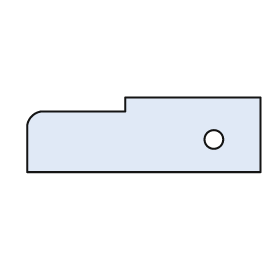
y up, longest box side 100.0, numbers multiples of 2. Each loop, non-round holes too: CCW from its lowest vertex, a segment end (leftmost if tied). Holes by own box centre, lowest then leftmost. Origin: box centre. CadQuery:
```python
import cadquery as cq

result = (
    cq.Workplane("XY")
    .moveTo(-50.0, -16.0)
    .lineTo(50.0, -16.0)
    .lineTo(50.0, 16.0)
    .lineTo(-8.0, 16.0)
    .lineTo(-8.0, 10.0)
    .lineTo(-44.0, 10.0)
    .threePointArc((-48.0, 8.0), (-50.0, 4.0))
    .close()
    .moveTo(30.0, -2.0)
    .circle(4.0)
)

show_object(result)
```